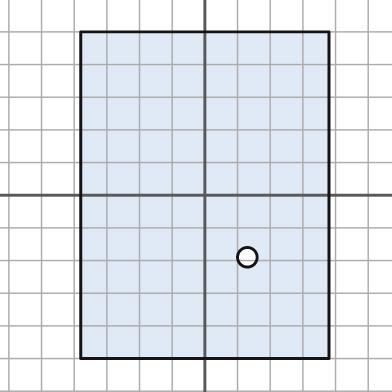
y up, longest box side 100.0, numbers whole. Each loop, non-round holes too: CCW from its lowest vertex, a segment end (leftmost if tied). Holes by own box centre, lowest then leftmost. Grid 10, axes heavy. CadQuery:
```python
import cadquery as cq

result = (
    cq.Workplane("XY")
    .moveTo(-38.0, -50.0)
    .lineTo(38.0, -50.0)
    .lineTo(38.0, 50.0)
    .lineTo(-38.0, 50.0)
    .close()
    .moveTo(13.0, -19.0)
    .circle(3.0)
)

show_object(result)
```